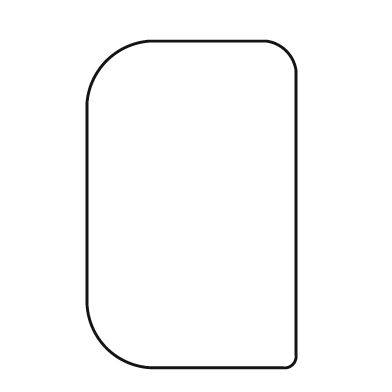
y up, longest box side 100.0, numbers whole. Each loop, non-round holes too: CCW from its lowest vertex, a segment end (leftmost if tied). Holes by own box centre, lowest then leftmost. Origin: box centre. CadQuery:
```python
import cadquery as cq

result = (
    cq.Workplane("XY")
    .moveTo(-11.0, -50.0)
    .lineTo(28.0, -50.0)
    .threePointArc((31.0, -49.0), (32.0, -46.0))
    .lineTo(32.0, 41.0)
    .threePointArc((29.0, 47.0), (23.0, 50.0))
    .lineTo(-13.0, 50.0)
    .threePointArc((-26.0, 44.0), (-32.0, 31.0))
    .lineTo(-32.0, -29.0)
    .threePointArc((-26.0, -44.0), (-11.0, -50.0))
    .close()
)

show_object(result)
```